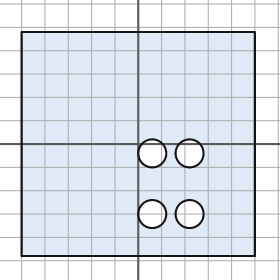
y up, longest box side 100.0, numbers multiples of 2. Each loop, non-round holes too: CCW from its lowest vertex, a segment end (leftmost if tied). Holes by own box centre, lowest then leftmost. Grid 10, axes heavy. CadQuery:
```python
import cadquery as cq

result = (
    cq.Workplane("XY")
    .moveTo(-50.0, -48.0)
    .lineTo(50.0, -48.0)
    .lineTo(50.0, 48.0)
    .lineTo(-50.0, 48.0)
    .close()
    .moveTo(6.0, -30.0)
    .circle(6.0)
    .moveTo(22.0, -30.0)
    .circle(6.0)
    .moveTo(6.0, -4.0)
    .circle(6.0)
    .moveTo(22.0, -4.0)
    .circle(6.0)
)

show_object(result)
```